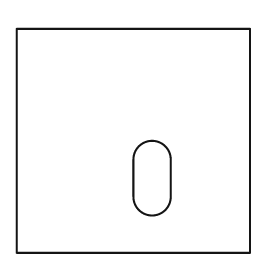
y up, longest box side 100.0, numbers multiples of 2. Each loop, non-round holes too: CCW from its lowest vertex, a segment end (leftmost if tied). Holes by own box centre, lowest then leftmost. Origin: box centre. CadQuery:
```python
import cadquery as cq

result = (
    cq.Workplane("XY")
    .moveTo(-50.0, -48.0)
    .lineTo(50.0, -48.0)
    .lineTo(50.0, 48.0)
    .lineTo(-50.0, 48.0)
    .close()
    .moveTo(0.0, -24.0)
    .threePointArc((8.0, -32.0), (16.0, -24.0))
    .lineTo(16.0, -8.0)
    .threePointArc((8.0, 0.0), (0.0, -8.0))
    .close()
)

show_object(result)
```